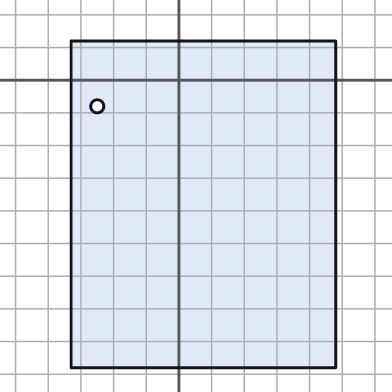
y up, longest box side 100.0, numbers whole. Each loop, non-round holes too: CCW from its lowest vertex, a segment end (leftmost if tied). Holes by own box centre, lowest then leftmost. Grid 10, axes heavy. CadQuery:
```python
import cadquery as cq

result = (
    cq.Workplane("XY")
    .moveTo(-33.0, -88.0)
    .lineTo(48.0, -88.0)
    .lineTo(48.0, 12.0)
    .lineTo(-33.0, 12.0)
    .close()
    .moveTo(-25.0, -8.0)
    .circle(2.0)
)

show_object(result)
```